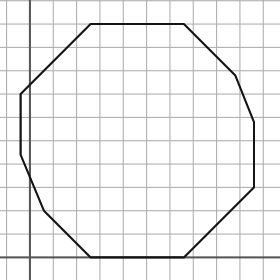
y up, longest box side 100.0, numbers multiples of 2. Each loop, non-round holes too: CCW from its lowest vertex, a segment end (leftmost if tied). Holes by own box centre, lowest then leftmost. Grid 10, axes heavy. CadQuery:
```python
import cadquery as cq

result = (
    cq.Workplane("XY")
    .moveTo(26.0, 0.0)
    .lineTo(66.0, 0.0)
    .lineTo(96.0, 30.0)
    .lineTo(96.0, 58.0)
    .lineTo(88.0, 78.0)
    .lineTo(66.0, 100.0)
    .lineTo(26.0, 100.0)
    .lineTo(-4.0, 70.0)
    .lineTo(-4.0, 44.0)
    .lineTo(6.0, 20.0)
    .close()
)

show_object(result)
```